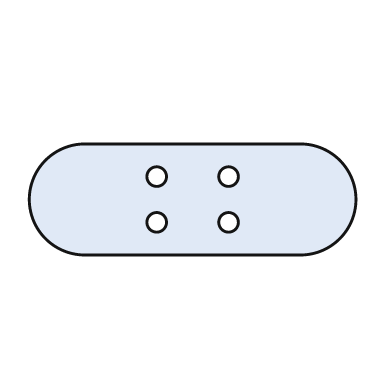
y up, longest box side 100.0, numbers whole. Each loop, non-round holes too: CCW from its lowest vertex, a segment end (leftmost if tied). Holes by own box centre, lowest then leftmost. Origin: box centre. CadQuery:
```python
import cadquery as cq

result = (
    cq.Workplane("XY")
    .moveTo(-33.0, -17.0)
    .lineTo(33.0, -17.0)
    .threePointArc((50.0, 0.0), (33.0, 17.0))
    .lineTo(-33.0, 17.0)
    .threePointArc((-50.0, 0.0), (-33.0, -17.0))
    .close()
    .moveTo(-11.0, -7.0)
    .circle(3.0)
    .moveTo(11.0, -7.0)
    .circle(3.0)
    .moveTo(-11.0, 7.0)
    .circle(3.0)
    .moveTo(11.0, 7.0)
    .circle(3.0)
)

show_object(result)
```